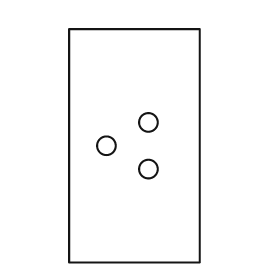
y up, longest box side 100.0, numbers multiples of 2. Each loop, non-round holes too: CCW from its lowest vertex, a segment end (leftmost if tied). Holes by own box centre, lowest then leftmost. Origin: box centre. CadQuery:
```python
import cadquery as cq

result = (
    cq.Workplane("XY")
    .moveTo(-28.0, -50.0)
    .lineTo(28.0, -50.0)
    .lineTo(28.0, 50.0)
    .lineTo(-28.0, 50.0)
    .close()
    .moveTo(6.0, -10.0)
    .circle(4.0)
    .moveTo(-12.0, 0.0)
    .circle(4.0)
    .moveTo(6.0, 10.0)
    .circle(4.0)
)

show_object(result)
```